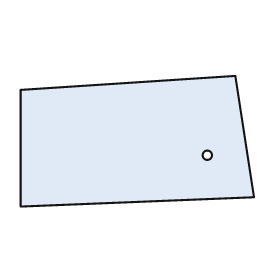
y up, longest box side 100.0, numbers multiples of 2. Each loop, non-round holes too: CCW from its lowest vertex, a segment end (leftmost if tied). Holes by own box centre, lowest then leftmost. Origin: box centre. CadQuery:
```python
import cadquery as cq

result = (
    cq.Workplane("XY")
    .moveTo(-50.0, -28.0)
    .lineTo(50.0, -24.0)
    .lineTo(42.0, 28.0)
    .lineTo(-50.0, 22.0)
    .close()
    .moveTo(30.0, -6.0)
    .circle(2.0)
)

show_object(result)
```